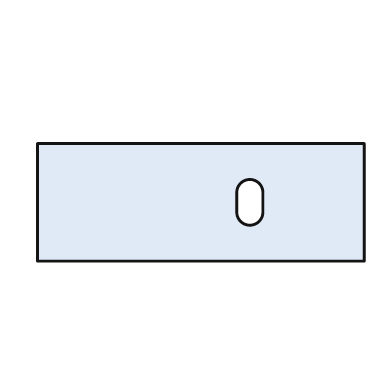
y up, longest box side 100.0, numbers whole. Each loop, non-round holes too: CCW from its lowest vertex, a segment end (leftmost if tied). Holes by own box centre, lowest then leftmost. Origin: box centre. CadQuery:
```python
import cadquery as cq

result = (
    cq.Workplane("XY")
    .moveTo(-50.0, -18.0)
    .lineTo(50.0, -18.0)
    .lineTo(50.0, 18.0)
    .lineTo(-50.0, 18.0)
    .close()
    .moveTo(11.0, -3.0)
    .threePointArc((15.0, -7.0), (19.0, -3.0))
    .lineTo(19.0, 3.0)
    .threePointArc((15.0, 7.0), (11.0, 3.0))
    .close()
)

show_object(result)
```